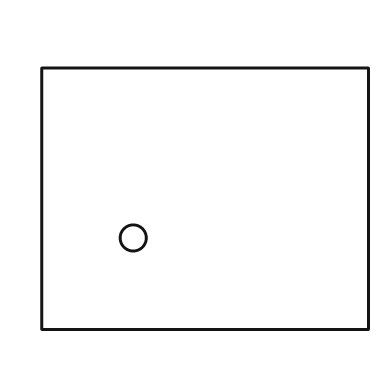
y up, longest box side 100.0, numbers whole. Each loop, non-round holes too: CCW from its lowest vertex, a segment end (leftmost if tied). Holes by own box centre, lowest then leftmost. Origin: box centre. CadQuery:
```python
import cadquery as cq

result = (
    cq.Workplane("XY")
    .moveTo(-50.0, -40.0)
    .lineTo(50.0, -40.0)
    .lineTo(50.0, 40.0)
    .lineTo(-50.0, 40.0)
    .close()
    .moveTo(-22.0, -12.0)
    .circle(4.0)
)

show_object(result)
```